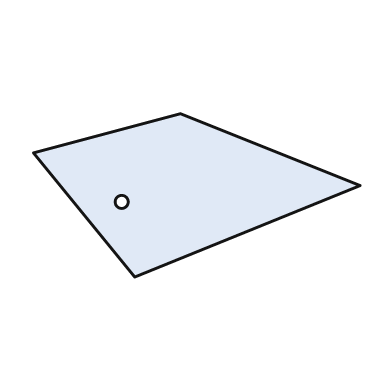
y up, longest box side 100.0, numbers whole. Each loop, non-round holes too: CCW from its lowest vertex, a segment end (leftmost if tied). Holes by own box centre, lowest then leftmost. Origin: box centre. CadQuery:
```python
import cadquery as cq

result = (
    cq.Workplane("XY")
    .moveTo(-19.0, -25.0)
    .lineTo(50.0, 3.0)
    .lineTo(-5.0, 25.0)
    .lineTo(-50.0, 13.0)
    .close()
    .moveTo(-23.0, -2.0)
    .circle(2.0)
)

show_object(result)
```